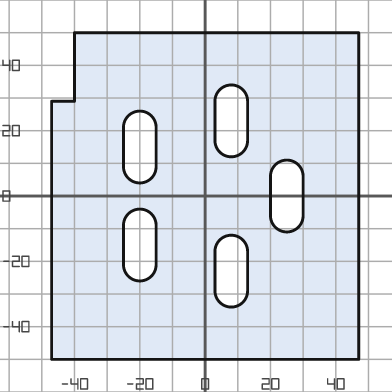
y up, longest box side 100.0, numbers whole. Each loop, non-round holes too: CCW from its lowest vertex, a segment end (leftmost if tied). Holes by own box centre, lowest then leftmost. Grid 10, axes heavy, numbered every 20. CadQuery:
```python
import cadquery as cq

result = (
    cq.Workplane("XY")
    .moveTo(-47.0, -50.0)
    .lineTo(47.0, -50.0)
    .lineTo(47.0, 50.0)
    .lineTo(-40.0, 50.0)
    .lineTo(-40.0, 29.0)
    .lineTo(-47.0, 29.0)
    .close()
    .moveTo(3.0, -29.0)
    .threePointArc((8.0, -34.0), (13.0, -29.0))
    .lineTo(13.0, -17.0)
    .threePointArc((8.0, -12.0), (3.0, -17.0))
    .close()
    .moveTo(-25.0, -21.0)
    .threePointArc((-20.0, -26.0), (-15.0, -21.0))
    .lineTo(-15.0, -9.0)
    .threePointArc((-20.0, -4.0), (-25.0, -9.0))
    .close()
    .moveTo(20.0, -6.0)
    .threePointArc((25.0, -11.0), (30.0, -6.0))
    .lineTo(30.0, 6.0)
    .threePointArc((25.0, 11.0), (20.0, 6.0))
    .close()
    .moveTo(-25.0, 9.0)
    .threePointArc((-20.0, 4.0), (-15.0, 9.0))
    .lineTo(-15.0, 21.0)
    .threePointArc((-20.0, 26.0), (-25.0, 21.0))
    .close()
    .moveTo(3.0, 17.0)
    .threePointArc((8.0, 12.0), (13.0, 17.0))
    .lineTo(13.0, 29.0)
    .threePointArc((8.0, 34.0), (3.0, 29.0))
    .close()
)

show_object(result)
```